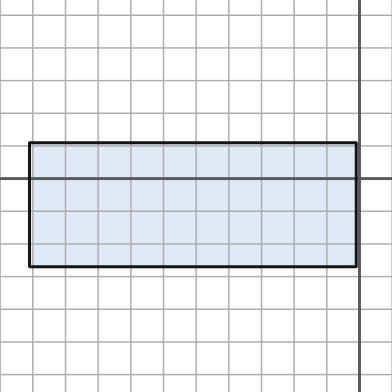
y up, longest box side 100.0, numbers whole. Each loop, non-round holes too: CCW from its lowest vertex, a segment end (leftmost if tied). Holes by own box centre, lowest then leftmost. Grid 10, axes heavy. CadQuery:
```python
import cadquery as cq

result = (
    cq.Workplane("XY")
    .moveTo(-101.0, -27.0)
    .lineTo(-1.0, -27.0)
    .lineTo(-1.0, 11.0)
    .lineTo(-101.0, 11.0)
    .close()
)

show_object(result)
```